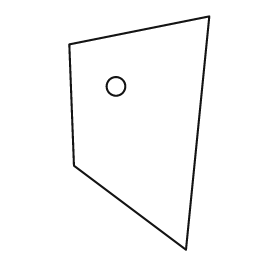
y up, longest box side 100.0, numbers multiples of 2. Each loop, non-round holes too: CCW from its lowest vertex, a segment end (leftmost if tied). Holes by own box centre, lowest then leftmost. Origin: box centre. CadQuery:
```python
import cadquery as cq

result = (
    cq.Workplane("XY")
    .moveTo(20.0, -50.0)
    .lineTo(30.0, 50.0)
    .lineTo(-30.0, 38.0)
    .lineTo(-28.0, -14.0)
    .close()
    .moveTo(-10.0, 20.0)
    .circle(4.0)
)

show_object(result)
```